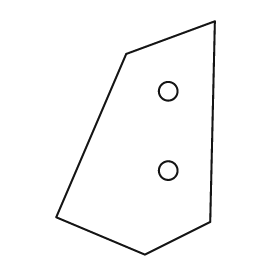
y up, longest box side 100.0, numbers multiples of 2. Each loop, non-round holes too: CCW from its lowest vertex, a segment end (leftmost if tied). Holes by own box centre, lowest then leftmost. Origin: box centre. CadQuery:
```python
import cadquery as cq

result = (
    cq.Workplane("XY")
    .moveTo(4.0, -50.0)
    .lineTo(32.0, -36.0)
    .lineTo(34.0, 50.0)
    .lineTo(-4.0, 36.0)
    .lineTo(-34.0, -34.0)
    .close()
    .moveTo(14.0, -14.0)
    .circle(4.0)
    .moveTo(14.0, 20.0)
    .circle(4.0)
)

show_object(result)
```